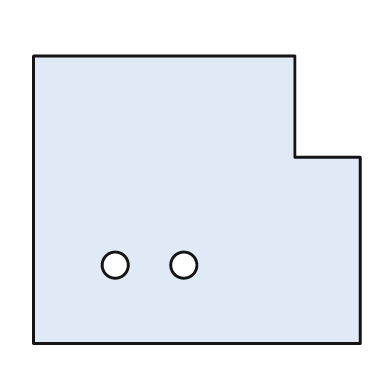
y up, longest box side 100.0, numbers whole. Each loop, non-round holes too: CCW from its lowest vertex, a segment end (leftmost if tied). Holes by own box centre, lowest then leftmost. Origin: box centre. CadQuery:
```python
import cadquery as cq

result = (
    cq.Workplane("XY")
    .moveTo(-50.0, -44.0)
    .lineTo(50.0, -44.0)
    .lineTo(50.0, 13.0)
    .lineTo(30.0, 13.0)
    .lineTo(30.0, 44.0)
    .lineTo(-50.0, 44.0)
    .close()
    .moveTo(-25.0, -20.0)
    .circle(4.0)
    .moveTo(-4.0, -20.0)
    .circle(4.0)
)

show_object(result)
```